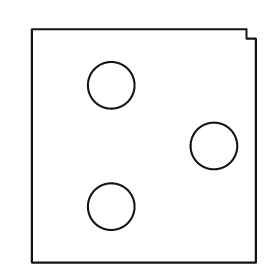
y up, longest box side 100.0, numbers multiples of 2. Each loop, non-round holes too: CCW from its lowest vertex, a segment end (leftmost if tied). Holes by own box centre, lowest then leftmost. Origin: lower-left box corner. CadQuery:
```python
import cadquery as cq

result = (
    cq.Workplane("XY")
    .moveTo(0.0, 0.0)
    .lineTo(96.0, 0.0)
    .lineTo(96.0, 96.0)
    .lineTo(92.0, 96.0)
    .lineTo(92.0, 100.0)
    .lineTo(0.0, 100.0)
    .close()
    .moveTo(34.0, 24.0)
    .circle(10.0)
    .moveTo(78.0, 50.0)
    .circle(10.0)
    .moveTo(34.0, 76.0)
    .circle(10.0)
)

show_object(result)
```